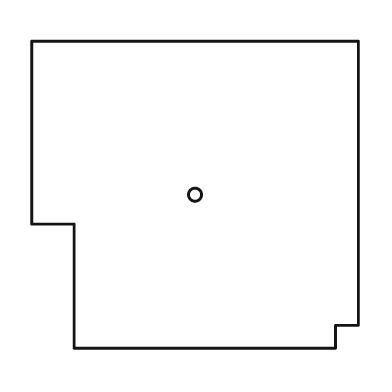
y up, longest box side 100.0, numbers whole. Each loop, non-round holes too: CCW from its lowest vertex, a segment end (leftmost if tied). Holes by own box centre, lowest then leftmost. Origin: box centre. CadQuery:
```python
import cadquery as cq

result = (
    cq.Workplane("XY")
    .moveTo(-37.0, -47.0)
    .lineTo(43.0, -47.0)
    .lineTo(43.0, -40.0)
    .lineTo(50.0, -40.0)
    .lineTo(50.0, 47.0)
    .lineTo(-50.0, 47.0)
    .lineTo(-50.0, -9.0)
    .lineTo(-37.0, -9.0)
    .close()
    .moveTo(0.0, 0.0)
    .circle(2.0)
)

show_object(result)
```